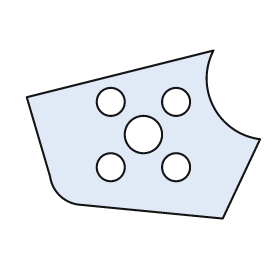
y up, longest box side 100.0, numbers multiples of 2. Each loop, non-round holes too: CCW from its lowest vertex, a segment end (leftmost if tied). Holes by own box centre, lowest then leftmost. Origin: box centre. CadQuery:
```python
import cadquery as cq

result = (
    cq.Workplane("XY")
    .moveTo(34.0, -36.0)
    .lineTo(50.0, -2.0)
    .threePointArc((30.0, 12.0), (30.0, 36.0))
    .lineTo(-50.0, 16.0)
    .lineTo(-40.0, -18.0)
    .threePointArc((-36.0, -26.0), (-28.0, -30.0))
    .close()
    .moveTo(-14.0, -14.0)
    .circle(6.0)
    .moveTo(14.0, -14.0)
    .circle(6.0)
    .moveTo(0.0, 0.0)
    .circle(8.0)
    .moveTo(-14.0, 14.0)
    .circle(6.0)
    .moveTo(14.0, 14.0)
    .circle(6.0)
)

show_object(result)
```